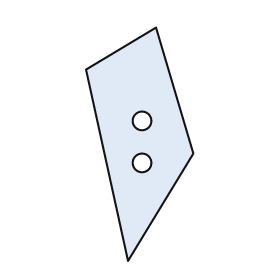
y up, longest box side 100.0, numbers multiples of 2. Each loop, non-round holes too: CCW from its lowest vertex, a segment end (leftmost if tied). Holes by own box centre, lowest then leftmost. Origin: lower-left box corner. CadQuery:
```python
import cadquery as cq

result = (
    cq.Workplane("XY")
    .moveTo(18.0, 0.0)
    .lineTo(46.0, 46.0)
    .lineTo(30.0, 100.0)
    .lineTo(0.0, 82.0)
    .close()
    .moveTo(24.0, 42.0)
    .circle(4.0)
    .moveTo(24.0, 60.0)
    .circle(4.0)
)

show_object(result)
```